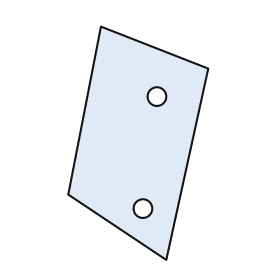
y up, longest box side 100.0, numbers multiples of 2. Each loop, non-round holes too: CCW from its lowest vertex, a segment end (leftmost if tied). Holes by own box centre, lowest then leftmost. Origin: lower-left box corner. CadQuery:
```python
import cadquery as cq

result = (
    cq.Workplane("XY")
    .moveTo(42.0, 0.0)
    .lineTo(60.0, 82.0)
    .lineTo(14.0, 100.0)
    .lineTo(0.0, 28.0)
    .close()
    .moveTo(32.0, 22.0)
    .circle(4.0)
    .moveTo(38.0, 70.0)
    .circle(4.0)
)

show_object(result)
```